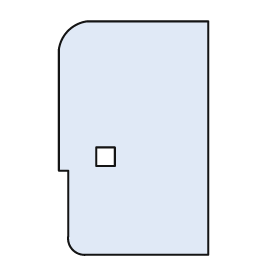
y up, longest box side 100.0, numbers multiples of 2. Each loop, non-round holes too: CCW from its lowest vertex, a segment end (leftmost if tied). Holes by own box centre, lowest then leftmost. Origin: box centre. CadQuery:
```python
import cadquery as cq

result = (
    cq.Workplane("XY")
    .moveTo(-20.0, -50.0)
    .lineTo(32.0, -50.0)
    .lineTo(32.0, 50.0)
    .lineTo(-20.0, 50.0)
    .threePointArc((-28.0, 46.0), (-32.0, 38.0))
    .lineTo(-32.0, -14.0)
    .lineTo(-28.0, -14.0)
    .lineTo(-28.0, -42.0)
    .threePointArc((-26.0, -48.0), (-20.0, -50.0))
    .close()
    .moveTo(-16.0, -12.0)
    .lineTo(-8.0, -12.0)
    .lineTo(-8.0, -4.0)
    .lineTo(-16.0, -4.0)
    .close()
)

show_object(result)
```